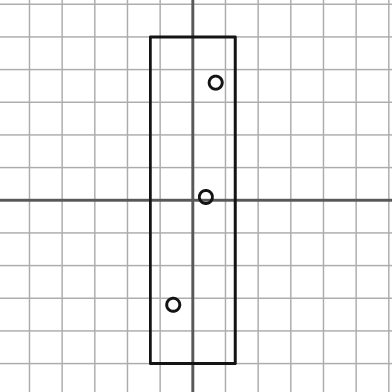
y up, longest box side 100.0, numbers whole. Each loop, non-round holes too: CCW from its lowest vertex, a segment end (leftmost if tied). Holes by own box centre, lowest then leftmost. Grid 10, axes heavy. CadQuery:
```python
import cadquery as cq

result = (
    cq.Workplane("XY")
    .moveTo(-13.0, -50.0)
    .lineTo(13.0, -50.0)
    .lineTo(13.0, 50.0)
    .lineTo(-13.0, 50.0)
    .close()
    .moveTo(-6.0, -32.0)
    .circle(2.0)
    .moveTo(4.0, 1.0)
    .circle(2.0)
    .moveTo(7.0, 36.0)
    .circle(2.0)
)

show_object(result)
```